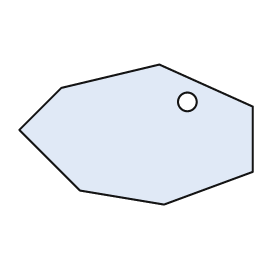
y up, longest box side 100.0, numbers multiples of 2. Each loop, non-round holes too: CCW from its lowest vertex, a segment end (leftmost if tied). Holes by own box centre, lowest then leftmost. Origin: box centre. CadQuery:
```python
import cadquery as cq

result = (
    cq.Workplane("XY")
    .moveTo(12.0, -30.0)
    .lineTo(50.0, -16.0)
    .lineTo(50.0, 12.0)
    .lineTo(10.0, 30.0)
    .lineTo(-32.0, 20.0)
    .lineTo(-50.0, 2.0)
    .lineTo(-24.0, -24.0)
    .close()
    .moveTo(22.0, 14.0)
    .circle(4.0)
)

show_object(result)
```